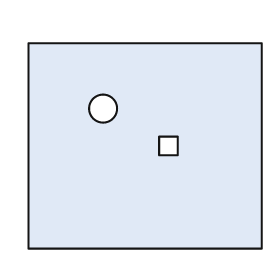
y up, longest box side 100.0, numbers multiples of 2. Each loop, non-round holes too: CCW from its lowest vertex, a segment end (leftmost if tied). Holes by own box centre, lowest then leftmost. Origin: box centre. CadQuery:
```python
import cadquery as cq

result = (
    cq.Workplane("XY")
    .moveTo(-50.0, -44.0)
    .lineTo(50.0, -44.0)
    .lineTo(50.0, 44.0)
    .lineTo(-50.0, 44.0)
    .close()
    .moveTo(6.0, -4.0)
    .lineTo(14.0, -4.0)
    .lineTo(14.0, 4.0)
    .lineTo(6.0, 4.0)
    .close()
    .moveTo(-18.0, 16.0)
    .circle(6.0)
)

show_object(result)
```